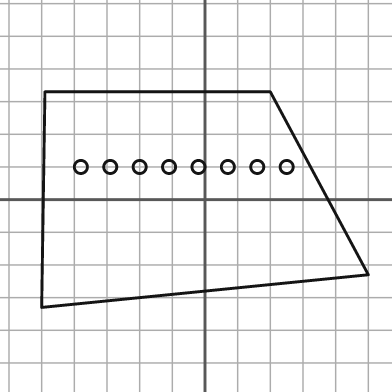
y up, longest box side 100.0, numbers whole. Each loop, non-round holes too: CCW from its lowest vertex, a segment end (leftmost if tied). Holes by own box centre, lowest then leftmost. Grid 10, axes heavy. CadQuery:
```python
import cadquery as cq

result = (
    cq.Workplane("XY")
    .moveTo(-50.0, -33.0)
    .lineTo(50.0, -23.0)
    .lineTo(20.0, 33.0)
    .lineTo(-49.0, 33.0)
    .close()
    .moveTo(-38.0, 10.0)
    .circle(2.0)
    .moveTo(-29.0, 10.0)
    .circle(2.0)
    .moveTo(-20.0, 10.0)
    .circle(2.0)
    .moveTo(-11.0, 10.0)
    .circle(2.0)
    .moveTo(-2.0, 10.0)
    .circle(2.0)
    .moveTo(7.0, 10.0)
    .circle(2.0)
    .moveTo(16.0, 10.0)
    .circle(2.0)
    .moveTo(25.0, 10.0)
    .circle(2.0)
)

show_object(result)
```